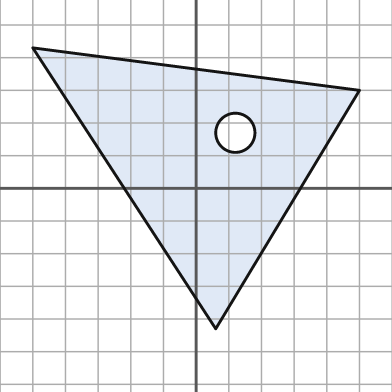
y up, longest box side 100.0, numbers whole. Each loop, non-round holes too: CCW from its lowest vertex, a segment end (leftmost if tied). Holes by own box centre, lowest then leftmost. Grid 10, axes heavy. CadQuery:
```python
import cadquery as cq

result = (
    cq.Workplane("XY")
    .moveTo(6.0, -43.0)
    .lineTo(50.0, 30.0)
    .lineTo(-50.0, 43.0)
    .close()
    .moveTo(12.0, 17.0)
    .circle(6.0)
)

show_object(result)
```